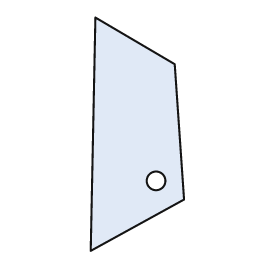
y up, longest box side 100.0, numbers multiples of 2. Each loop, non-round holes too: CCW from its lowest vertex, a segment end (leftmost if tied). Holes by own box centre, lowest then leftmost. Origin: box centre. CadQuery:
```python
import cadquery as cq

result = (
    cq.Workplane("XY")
    .moveTo(-20.0, -50.0)
    .lineTo(20.0, -28.0)
    .lineTo(16.0, 30.0)
    .lineTo(-18.0, 50.0)
    .close()
    .moveTo(8.0, -20.0)
    .circle(4.0)
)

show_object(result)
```